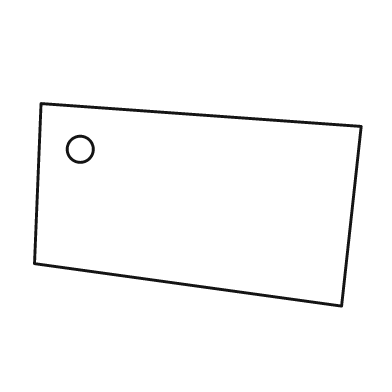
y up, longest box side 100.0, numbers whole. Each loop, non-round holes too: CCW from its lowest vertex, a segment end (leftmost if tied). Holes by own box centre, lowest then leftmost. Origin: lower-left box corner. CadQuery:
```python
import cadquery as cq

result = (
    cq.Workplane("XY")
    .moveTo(94.0, 0.0)
    .lineTo(100.0, 55.0)
    .lineTo(2.0, 62.0)
    .lineTo(0.0, 13.0)
    .close()
    .moveTo(14.0, 48.0)
    .circle(4.0)
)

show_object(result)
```